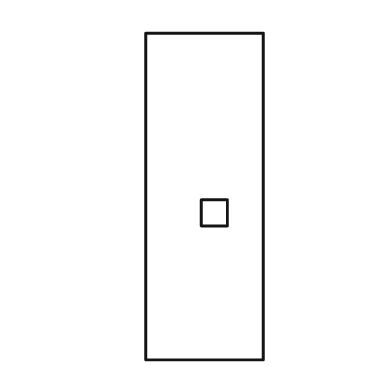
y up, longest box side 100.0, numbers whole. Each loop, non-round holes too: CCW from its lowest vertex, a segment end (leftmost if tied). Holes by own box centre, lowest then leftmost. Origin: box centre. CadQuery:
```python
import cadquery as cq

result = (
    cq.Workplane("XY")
    .moveTo(-18.0, -50.0)
    .lineTo(18.0, -50.0)
    .lineTo(18.0, 50.0)
    .lineTo(-18.0, 50.0)
    .close()
    .moveTo(-1.0, -9.0)
    .lineTo(7.0, -9.0)
    .lineTo(7.0, -1.0)
    .lineTo(-1.0, -1.0)
    .close()
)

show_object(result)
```